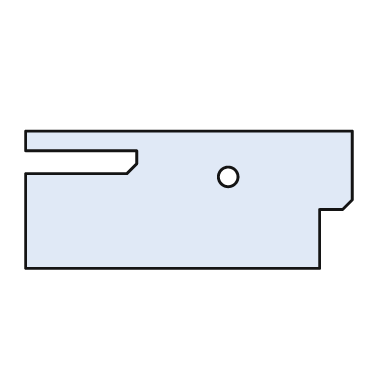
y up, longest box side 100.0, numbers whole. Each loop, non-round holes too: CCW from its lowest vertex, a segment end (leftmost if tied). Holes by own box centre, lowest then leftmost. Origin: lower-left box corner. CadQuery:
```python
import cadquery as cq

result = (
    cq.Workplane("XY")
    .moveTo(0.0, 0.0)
    .lineTo(90.0, 0.0)
    .lineTo(90.0, 18.0)
    .lineTo(97.0, 18.0)
    .lineTo(100.0, 21.0)
    .lineTo(100.0, 42.0)
    .lineTo(0.0, 42.0)
    .lineTo(0.0, 36.0)
    .lineTo(34.0, 36.0)
    .lineTo(34.0, 32.0)
    .lineTo(31.0, 29.0)
    .lineTo(0.0, 29.0)
    .close()
    .moveTo(62.0, 28.0)
    .circle(3.0)
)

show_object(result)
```